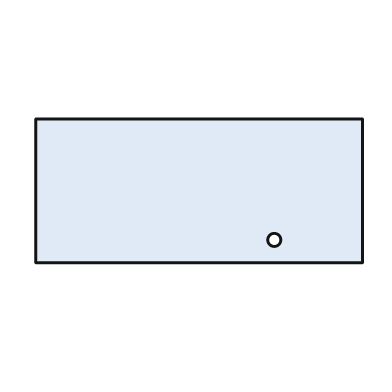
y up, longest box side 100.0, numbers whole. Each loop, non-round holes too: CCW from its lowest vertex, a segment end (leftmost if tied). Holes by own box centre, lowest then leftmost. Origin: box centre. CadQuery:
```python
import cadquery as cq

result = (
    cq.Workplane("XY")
    .moveTo(-50.0, -22.0)
    .lineTo(50.0, -22.0)
    .lineTo(50.0, 22.0)
    .lineTo(-50.0, 22.0)
    .close()
    .moveTo(23.0, -15.0)
    .circle(2.0)
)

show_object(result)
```